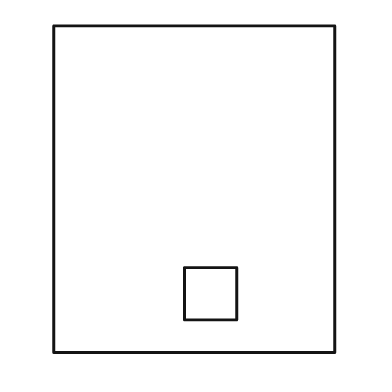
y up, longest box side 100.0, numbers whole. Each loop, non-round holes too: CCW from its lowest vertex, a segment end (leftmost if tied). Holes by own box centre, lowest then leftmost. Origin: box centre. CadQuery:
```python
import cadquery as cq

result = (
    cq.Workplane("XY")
    .moveTo(-43.0, -50.0)
    .lineTo(43.0, -50.0)
    .lineTo(43.0, 50.0)
    .lineTo(-43.0, 50.0)
    .close()
    .moveTo(-3.0, -40.0)
    .lineTo(13.0, -40.0)
    .lineTo(13.0, -24.0)
    .lineTo(-3.0, -24.0)
    .close()
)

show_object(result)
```